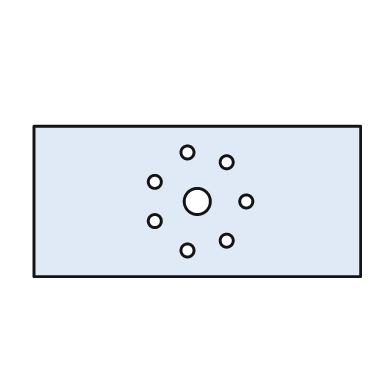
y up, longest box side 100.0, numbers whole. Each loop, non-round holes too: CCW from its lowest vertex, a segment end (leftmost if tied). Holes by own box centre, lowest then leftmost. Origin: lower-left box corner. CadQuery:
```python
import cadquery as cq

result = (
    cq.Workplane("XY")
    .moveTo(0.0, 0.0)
    .lineTo(100.0, 0.0)
    .lineTo(100.0, 46.0)
    .lineTo(0.0, 46.0)
    .close()
    .moveTo(47.0, 8.0)
    .circle(2.0)
    .moveTo(59.0, 11.0)
    .circle(2.0)
    .moveTo(37.0, 17.0)
    .circle(2.0)
    .moveTo(50.0, 23.0)
    .circle(4.0)
    .moveTo(65.0, 23.0)
    .circle(2.0)
    .moveTo(37.0, 29.0)
    .circle(2.0)
    .moveTo(59.0, 35.0)
    .circle(2.0)
    .moveTo(47.0, 38.0)
    .circle(2.0)
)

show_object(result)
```